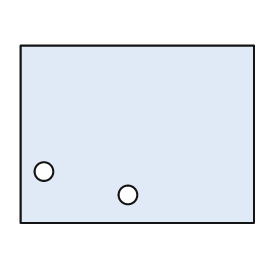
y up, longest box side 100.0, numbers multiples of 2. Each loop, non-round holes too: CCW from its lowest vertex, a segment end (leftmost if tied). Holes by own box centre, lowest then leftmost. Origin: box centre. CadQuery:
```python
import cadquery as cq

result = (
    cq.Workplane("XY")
    .moveTo(-50.0, -38.0)
    .lineTo(50.0, -38.0)
    .lineTo(50.0, 38.0)
    .lineTo(-50.0, 38.0)
    .close()
    .moveTo(-4.0, -26.0)
    .circle(4.0)
    .moveTo(-40.0, -16.0)
    .circle(4.0)
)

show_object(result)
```